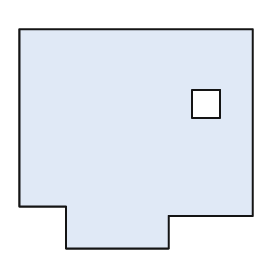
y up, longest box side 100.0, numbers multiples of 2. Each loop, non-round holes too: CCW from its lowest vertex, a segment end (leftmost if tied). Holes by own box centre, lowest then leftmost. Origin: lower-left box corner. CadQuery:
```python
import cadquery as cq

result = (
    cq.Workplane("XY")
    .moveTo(20.0, 0.0)
    .lineTo(64.0, 0.0)
    .lineTo(64.0, 14.0)
    .lineTo(100.0, 14.0)
    .lineTo(100.0, 94.0)
    .lineTo(0.0, 94.0)
    .lineTo(0.0, 18.0)
    .lineTo(20.0, 18.0)
    .close()
    .moveTo(74.0, 56.0)
    .lineTo(86.0, 56.0)
    .lineTo(86.0, 68.0)
    .lineTo(74.0, 68.0)
    .close()
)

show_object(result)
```